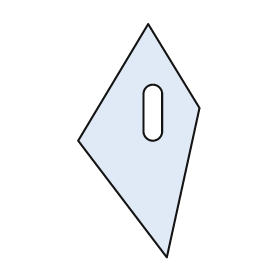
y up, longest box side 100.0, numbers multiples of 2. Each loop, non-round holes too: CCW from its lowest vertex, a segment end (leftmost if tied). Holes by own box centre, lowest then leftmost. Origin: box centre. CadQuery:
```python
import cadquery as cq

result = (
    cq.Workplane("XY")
    .moveTo(12.0, -50.0)
    .lineTo(26.0, 14.0)
    .lineTo(4.0, 50.0)
    .lineTo(-26.0, 0.0)
    .close()
    .moveTo(2.0, 4.0)
    .threePointArc((6.0, 0.0), (10.0, 4.0))
    .lineTo(10.0, 20.0)
    .threePointArc((6.0, 24.0), (2.0, 20.0))
    .close()
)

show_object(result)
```